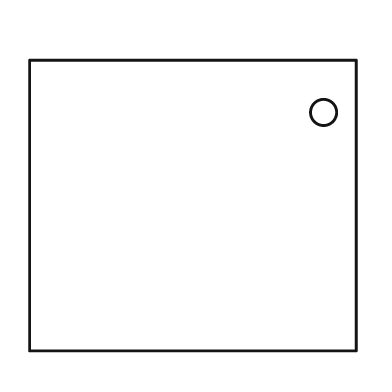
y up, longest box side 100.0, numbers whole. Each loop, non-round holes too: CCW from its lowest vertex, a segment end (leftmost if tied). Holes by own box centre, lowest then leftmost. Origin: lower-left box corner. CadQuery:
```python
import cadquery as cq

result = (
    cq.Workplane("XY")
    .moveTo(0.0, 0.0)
    .lineTo(100.0, 0.0)
    .lineTo(100.0, 89.0)
    .lineTo(0.0, 89.0)
    .close()
    .moveTo(90.0, 73.0)
    .circle(4.0)
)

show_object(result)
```